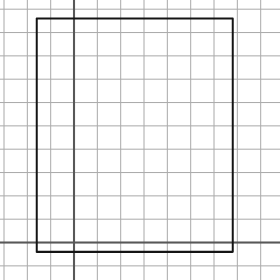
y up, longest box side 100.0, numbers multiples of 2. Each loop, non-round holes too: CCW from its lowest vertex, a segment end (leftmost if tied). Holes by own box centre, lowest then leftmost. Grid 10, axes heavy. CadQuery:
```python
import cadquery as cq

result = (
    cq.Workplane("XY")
    .moveTo(-16.0, -4.0)
    .lineTo(68.0, -4.0)
    .lineTo(68.0, 96.0)
    .lineTo(-16.0, 96.0)
    .close()
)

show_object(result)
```